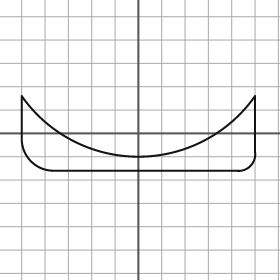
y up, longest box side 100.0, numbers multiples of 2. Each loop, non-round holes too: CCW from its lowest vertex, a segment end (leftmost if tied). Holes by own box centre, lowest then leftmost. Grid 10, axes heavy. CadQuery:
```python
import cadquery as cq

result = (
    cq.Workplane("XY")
    .moveTo(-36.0, -16.0)
    .lineTo(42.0, -16.0)
    .threePointArc((48.0, -14.0), (50.0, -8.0))
    .lineTo(50.0, 16.0)
    .threePointArc((0.0, -10.0), (-50.0, 16.0))
    .lineTo(-50.0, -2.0)
    .threePointArc((-46.0, -12.0), (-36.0, -16.0))
    .close()
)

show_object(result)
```